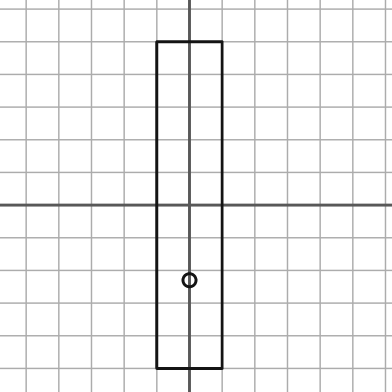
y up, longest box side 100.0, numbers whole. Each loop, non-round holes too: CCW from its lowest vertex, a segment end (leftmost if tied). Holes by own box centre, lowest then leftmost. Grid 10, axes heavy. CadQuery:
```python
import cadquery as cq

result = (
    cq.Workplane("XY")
    .moveTo(-10.0, -50.0)
    .lineTo(10.0, -50.0)
    .lineTo(10.0, 50.0)
    .lineTo(-10.0, 50.0)
    .close()
    .moveTo(0.0, -23.0)
    .circle(2.0)
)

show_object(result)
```